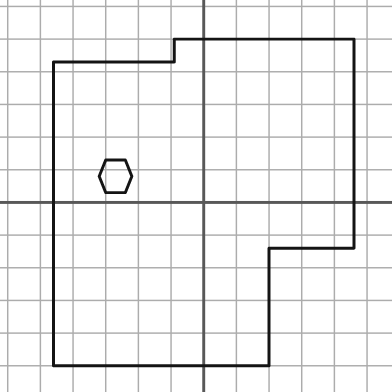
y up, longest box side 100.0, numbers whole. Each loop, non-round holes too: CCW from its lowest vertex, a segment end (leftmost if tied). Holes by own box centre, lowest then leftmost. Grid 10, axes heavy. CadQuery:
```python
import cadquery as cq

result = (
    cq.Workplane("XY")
    .moveTo(-46.0, -50.0)
    .lineTo(20.0, -50.0)
    .lineTo(20.0, -14.0)
    .lineTo(46.0, -14.0)
    .lineTo(46.0, 50.0)
    .lineTo(-9.0, 50.0)
    .lineTo(-9.0, 43.0)
    .lineTo(-46.0, 43.0)
    .close()
    .moveTo(-30.0, 3.0)
    .lineTo(-24.0, 3.0)
    .lineTo(-22.0, 8.0)
    .lineTo(-24.0, 13.0)
    .lineTo(-30.0, 13.0)
    .lineTo(-32.0, 8.0)
    .close()
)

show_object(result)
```